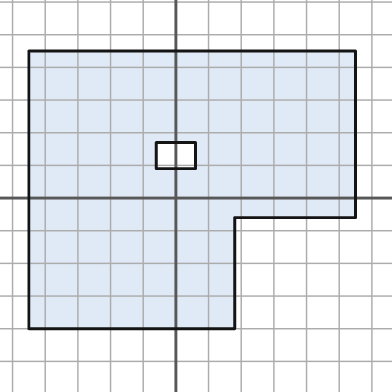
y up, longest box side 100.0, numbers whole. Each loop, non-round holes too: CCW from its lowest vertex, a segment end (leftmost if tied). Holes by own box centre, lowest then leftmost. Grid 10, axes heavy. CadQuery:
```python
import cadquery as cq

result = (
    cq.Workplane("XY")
    .moveTo(-45.0, -40.0)
    .lineTo(18.0, -40.0)
    .lineTo(18.0, -6.0)
    .lineTo(55.0, -6.0)
    .lineTo(55.0, 45.0)
    .lineTo(-45.0, 45.0)
    .close()
    .moveTo(-6.0, 9.0)
    .lineTo(6.0, 9.0)
    .lineTo(6.0, 17.0)
    .lineTo(-6.0, 17.0)
    .close()
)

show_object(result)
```